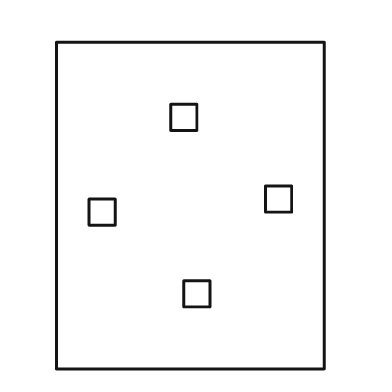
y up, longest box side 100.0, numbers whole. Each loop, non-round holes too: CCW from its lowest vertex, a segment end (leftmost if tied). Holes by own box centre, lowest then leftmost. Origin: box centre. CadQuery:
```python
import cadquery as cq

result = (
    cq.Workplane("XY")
    .moveTo(-41.0, -50.0)
    .lineTo(41.0, -50.0)
    .lineTo(41.0, 50.0)
    .lineTo(-41.0, 50.0)
    .close()
    .moveTo(-2.0, -31.0)
    .lineTo(6.0, -31.0)
    .lineTo(6.0, -23.0)
    .lineTo(-2.0, -23.0)
    .close()
    .moveTo(-31.0, -6.0)
    .lineTo(-23.0, -6.0)
    .lineTo(-23.0, 2.0)
    .lineTo(-31.0, 2.0)
    .close()
    .moveTo(23.0, -2.0)
    .lineTo(31.0, -2.0)
    .lineTo(31.0, 6.0)
    .lineTo(23.0, 6.0)
    .close()
    .moveTo(-6.0, 23.0)
    .lineTo(2.0, 23.0)
    .lineTo(2.0, 31.0)
    .lineTo(-6.0, 31.0)
    .close()
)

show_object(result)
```